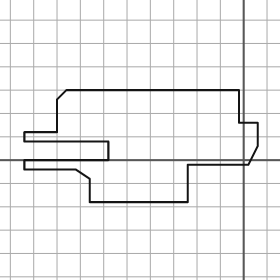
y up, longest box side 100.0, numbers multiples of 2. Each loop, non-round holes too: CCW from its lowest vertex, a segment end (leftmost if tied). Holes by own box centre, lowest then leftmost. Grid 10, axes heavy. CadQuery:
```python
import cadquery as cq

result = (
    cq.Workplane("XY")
    .moveTo(-66.0, -18.0)
    .lineTo(-24.0, -18.0)
    .lineTo(-24.0, -2.0)
    .lineTo(2.0, -2.0)
    .lineTo(6.0, 6.0)
    .lineTo(6.0, 16.0)
    .lineTo(-2.0, 16.0)
    .lineTo(-2.0, 30.0)
    .lineTo(-76.0, 30.0)
    .lineTo(-80.0, 26.0)
    .lineTo(-80.0, 12.0)
    .lineTo(-94.0, 12.0)
    .lineTo(-94.0, 8.0)
    .lineTo(-58.0, 8.0)
    .lineTo(-58.0, 0.0)
    .lineTo(-94.0, 0.0)
    .lineTo(-94.0, -4.0)
    .lineTo(-72.0, -4.0)
    .lineTo(-66.0, -8.0)
    .close()
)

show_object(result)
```